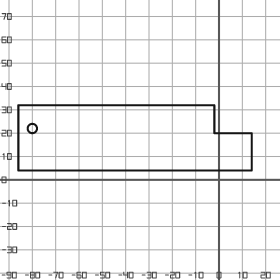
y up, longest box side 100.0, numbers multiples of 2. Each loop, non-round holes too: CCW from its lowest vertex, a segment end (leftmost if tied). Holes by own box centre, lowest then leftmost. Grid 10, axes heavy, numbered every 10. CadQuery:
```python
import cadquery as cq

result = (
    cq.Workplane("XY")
    .moveTo(-86.0, 4.0)
    .lineTo(14.0, 4.0)
    .lineTo(14.0, 20.0)
    .lineTo(-2.0, 20.0)
    .lineTo(-2.0, 32.0)
    .lineTo(-86.0, 32.0)
    .close()
    .moveTo(-80.0, 22.0)
    .circle(2.0)
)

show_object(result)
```